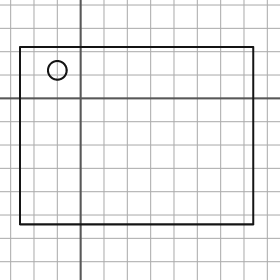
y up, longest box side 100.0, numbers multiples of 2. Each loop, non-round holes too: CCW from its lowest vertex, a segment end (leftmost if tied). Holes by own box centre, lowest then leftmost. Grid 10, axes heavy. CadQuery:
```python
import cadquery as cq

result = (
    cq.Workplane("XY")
    .moveTo(-26.0, -54.0)
    .lineTo(74.0, -54.0)
    .lineTo(74.0, 22.0)
    .lineTo(-26.0, 22.0)
    .close()
    .moveTo(-10.0, 12.0)
    .circle(4.0)
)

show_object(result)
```